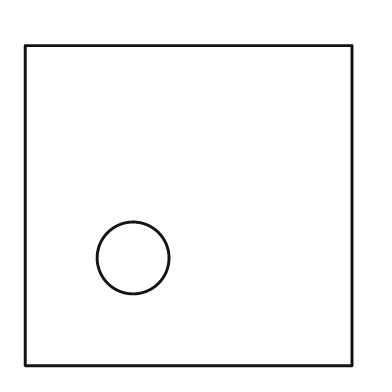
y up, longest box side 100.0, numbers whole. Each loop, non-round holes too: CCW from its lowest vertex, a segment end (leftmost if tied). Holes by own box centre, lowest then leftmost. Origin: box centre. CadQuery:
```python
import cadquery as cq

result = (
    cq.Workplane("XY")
    .moveTo(-50.0, -49.0)
    .lineTo(50.0, -49.0)
    .lineTo(50.0, 49.0)
    .lineTo(-50.0, 49.0)
    .close()
    .moveTo(-17.0, -16.0)
    .circle(11.0)
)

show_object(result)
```